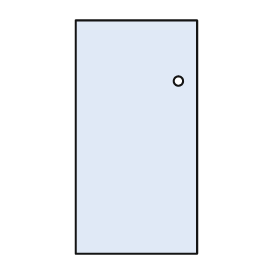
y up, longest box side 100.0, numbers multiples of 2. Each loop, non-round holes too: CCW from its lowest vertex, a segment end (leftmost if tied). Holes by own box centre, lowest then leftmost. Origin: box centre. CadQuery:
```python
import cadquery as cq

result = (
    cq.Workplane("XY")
    .moveTo(-26.0, -50.0)
    .lineTo(26.0, -50.0)
    .lineTo(26.0, 50.0)
    .lineTo(-26.0, 50.0)
    .close()
    .moveTo(18.0, 24.0)
    .circle(2.0)
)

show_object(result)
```